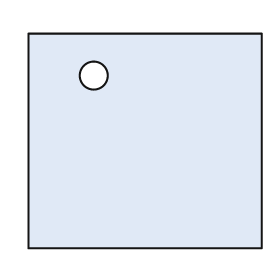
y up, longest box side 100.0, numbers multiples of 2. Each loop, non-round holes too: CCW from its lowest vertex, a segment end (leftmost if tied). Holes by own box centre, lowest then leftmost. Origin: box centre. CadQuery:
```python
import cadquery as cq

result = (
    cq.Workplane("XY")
    .moveTo(-50.0, -46.0)
    .lineTo(50.0, -46.0)
    .lineTo(50.0, 46.0)
    .lineTo(-50.0, 46.0)
    .close()
    .moveTo(-22.0, 28.0)
    .circle(6.0)
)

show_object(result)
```